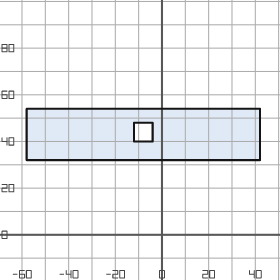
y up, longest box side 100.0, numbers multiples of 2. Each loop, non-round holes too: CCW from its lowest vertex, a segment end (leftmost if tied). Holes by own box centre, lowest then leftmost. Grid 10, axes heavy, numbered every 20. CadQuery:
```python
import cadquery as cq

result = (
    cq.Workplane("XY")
    .moveTo(-58.0, 32.0)
    .lineTo(42.0, 32.0)
    .lineTo(42.0, 54.0)
    .lineTo(-58.0, 54.0)
    .close()
    .moveTo(-12.0, 40.0)
    .lineTo(-4.0, 40.0)
    .lineTo(-4.0, 48.0)
    .lineTo(-12.0, 48.0)
    .close()
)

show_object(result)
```